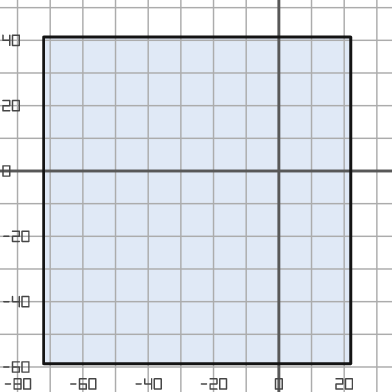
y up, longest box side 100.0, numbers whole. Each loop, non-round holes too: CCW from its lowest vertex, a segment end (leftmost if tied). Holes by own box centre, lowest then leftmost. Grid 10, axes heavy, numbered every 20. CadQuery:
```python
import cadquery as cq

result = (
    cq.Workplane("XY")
    .moveTo(-72.0, -59.0)
    .lineTo(22.0, -59.0)
    .lineTo(22.0, 41.0)
    .lineTo(-72.0, 41.0)
    .close()
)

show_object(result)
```